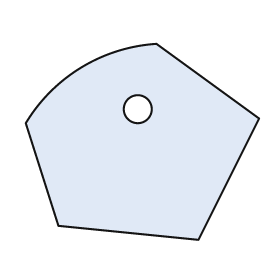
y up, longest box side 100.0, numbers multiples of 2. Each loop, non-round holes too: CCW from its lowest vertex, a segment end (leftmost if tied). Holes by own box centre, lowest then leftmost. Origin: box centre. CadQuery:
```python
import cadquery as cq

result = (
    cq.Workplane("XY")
    .moveTo(24.0, -42.0)
    .lineTo(50.0, 10.0)
    .lineTo(6.0, 42.0)
    .threePointArc((-26.0, 32.0), (-50.0, 8.0))
    .lineTo(-36.0, -36.0)
    .close()
    .moveTo(-2.0, 14.0)
    .circle(6.0)
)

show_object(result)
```